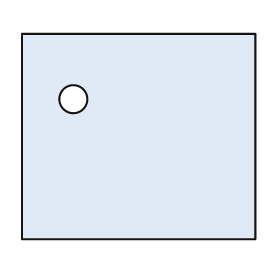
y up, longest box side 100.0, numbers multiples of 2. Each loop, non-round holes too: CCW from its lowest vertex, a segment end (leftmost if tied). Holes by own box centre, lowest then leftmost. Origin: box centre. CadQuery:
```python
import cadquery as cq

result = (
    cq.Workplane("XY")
    .moveTo(-50.0, -44.0)
    .lineTo(50.0, -44.0)
    .lineTo(50.0, 44.0)
    .lineTo(-50.0, 44.0)
    .close()
    .moveTo(-28.0, 16.0)
    .circle(6.0)
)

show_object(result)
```